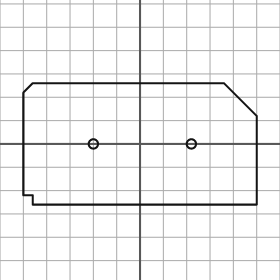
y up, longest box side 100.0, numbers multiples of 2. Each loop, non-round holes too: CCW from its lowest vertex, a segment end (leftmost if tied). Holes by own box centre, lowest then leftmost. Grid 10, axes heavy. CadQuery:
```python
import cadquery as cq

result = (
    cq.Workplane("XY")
    .moveTo(-46.0, -26.0)
    .lineTo(50.0, -26.0)
    .lineTo(50.0, 12.0)
    .lineTo(36.0, 26.0)
    .lineTo(-46.0, 26.0)
    .lineTo(-50.0, 22.0)
    .lineTo(-50.0, -22.0)
    .lineTo(-46.0, -22.0)
    .close()
    .moveTo(-20.0, 0.0)
    .circle(2.0)
    .moveTo(22.0, 0.0)
    .circle(2.0)
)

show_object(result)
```